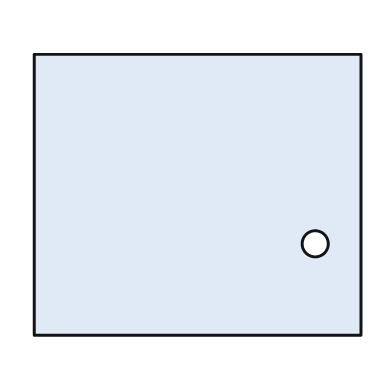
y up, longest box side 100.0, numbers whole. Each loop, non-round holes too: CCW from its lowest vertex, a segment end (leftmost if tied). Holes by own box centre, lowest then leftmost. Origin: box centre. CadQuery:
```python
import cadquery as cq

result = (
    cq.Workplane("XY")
    .moveTo(-50.0, -43.0)
    .lineTo(50.0, -43.0)
    .lineTo(50.0, 43.0)
    .lineTo(-50.0, 43.0)
    .close()
    .moveTo(36.0, -15.0)
    .circle(4.0)
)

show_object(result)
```